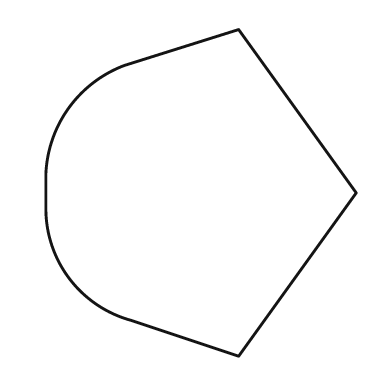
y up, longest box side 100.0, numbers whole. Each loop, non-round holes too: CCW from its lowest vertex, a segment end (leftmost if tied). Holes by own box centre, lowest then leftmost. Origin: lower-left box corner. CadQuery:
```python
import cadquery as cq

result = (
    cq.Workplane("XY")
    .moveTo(59.0, 0.0)
    .lineTo(95.0, 50.0)
    .lineTo(59.0, 100.0)
    .lineTo(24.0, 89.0)
    .threePointArc((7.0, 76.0), (0.0, 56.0))
    .lineTo(0.0, 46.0)
    .threePointArc((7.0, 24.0), (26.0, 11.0))
    .close()
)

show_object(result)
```